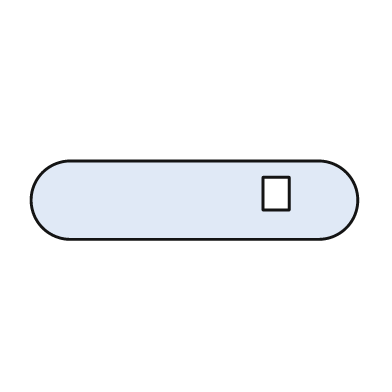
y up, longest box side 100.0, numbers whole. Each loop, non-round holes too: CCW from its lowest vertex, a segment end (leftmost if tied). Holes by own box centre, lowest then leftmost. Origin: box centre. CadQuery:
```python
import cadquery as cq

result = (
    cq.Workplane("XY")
    .moveTo(-38.0, -12.0)
    .lineTo(38.0, -12.0)
    .threePointArc((50.0, 0.0), (38.0, 12.0))
    .lineTo(-38.0, 12.0)
    .threePointArc((-50.0, 0.0), (-38.0, -12.0))
    .close()
    .moveTo(21.0, -3.0)
    .lineTo(29.0, -3.0)
    .lineTo(29.0, 7.0)
    .lineTo(21.0, 7.0)
    .close()
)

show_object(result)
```